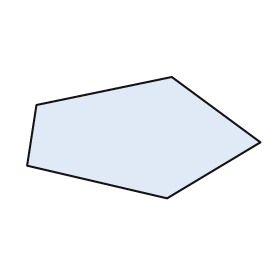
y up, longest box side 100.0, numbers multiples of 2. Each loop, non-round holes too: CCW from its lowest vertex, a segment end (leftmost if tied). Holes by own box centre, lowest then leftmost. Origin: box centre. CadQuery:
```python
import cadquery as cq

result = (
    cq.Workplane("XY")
    .moveTo(10.0, -26.0)
    .lineTo(50.0, -2.0)
    .lineTo(12.0, 26.0)
    .lineTo(-46.0, 14.0)
    .lineTo(-50.0, -12.0)
    .close()
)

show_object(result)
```